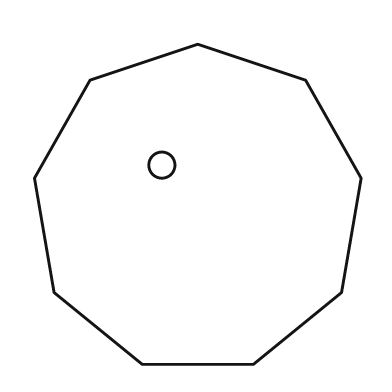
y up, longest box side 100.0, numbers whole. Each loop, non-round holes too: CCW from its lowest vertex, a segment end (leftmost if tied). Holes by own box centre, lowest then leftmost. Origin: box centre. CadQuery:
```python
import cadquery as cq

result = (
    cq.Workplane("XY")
    .moveTo(-17.0, -49.0)
    .lineTo(17.0, -49.0)
    .lineTo(44.0, -27.0)
    .lineTo(50.0, 8.0)
    .lineTo(33.0, 38.0)
    .lineTo(0.0, 49.0)
    .lineTo(-33.0, 38.0)
    .lineTo(-50.0, 8.0)
    .lineTo(-44.0, -27.0)
    .close()
    .moveTo(-11.0, 12.0)
    .circle(4.0)
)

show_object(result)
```